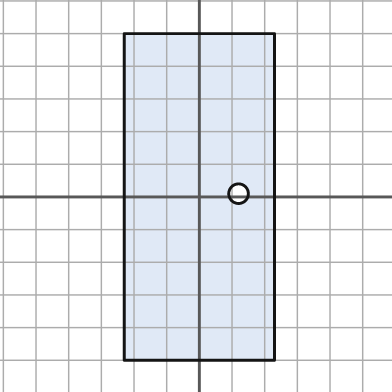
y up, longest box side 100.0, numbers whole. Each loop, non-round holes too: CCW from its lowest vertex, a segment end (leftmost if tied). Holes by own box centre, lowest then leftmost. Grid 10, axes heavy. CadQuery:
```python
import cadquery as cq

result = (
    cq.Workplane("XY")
    .moveTo(-23.0, -50.0)
    .lineTo(23.0, -50.0)
    .lineTo(23.0, 50.0)
    .lineTo(-23.0, 50.0)
    .close()
    .moveTo(12.0, 1.0)
    .circle(3.0)
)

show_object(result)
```